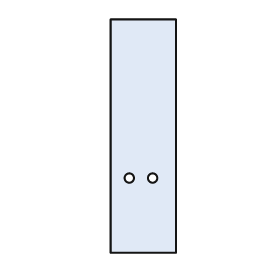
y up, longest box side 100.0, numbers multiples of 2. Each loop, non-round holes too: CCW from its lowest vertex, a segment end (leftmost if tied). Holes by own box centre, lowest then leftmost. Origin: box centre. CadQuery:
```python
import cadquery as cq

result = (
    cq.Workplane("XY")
    .moveTo(-14.0, -50.0)
    .lineTo(14.0, -50.0)
    .lineTo(14.0, 50.0)
    .lineTo(-14.0, 50.0)
    .close()
    .moveTo(-6.0, -18.0)
    .circle(2.0)
    .moveTo(4.0, -18.0)
    .circle(2.0)
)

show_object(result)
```